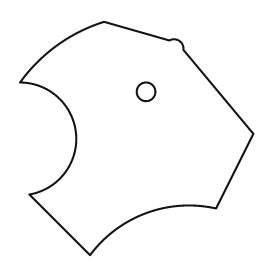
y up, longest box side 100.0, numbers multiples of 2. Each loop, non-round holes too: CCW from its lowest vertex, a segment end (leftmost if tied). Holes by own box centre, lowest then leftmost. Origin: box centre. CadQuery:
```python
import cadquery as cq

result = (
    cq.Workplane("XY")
    .moveTo(-20.0, -50.0)
    .threePointArc((4.0, -32.0), (34.0, -30.0))
    .lineTo(50.0, 2.0)
    .lineTo(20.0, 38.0)
    .threePointArc((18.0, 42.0), (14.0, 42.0))
    .lineTo(-14.0, 50.0)
    .threePointArc((-34.0, 40.0), (-50.0, 24.0))
    .threePointArc((-26.0, 2.0), (-46.0, -24.0))
    .close()
    .moveTo(4.0, 20.0)
    .circle(4.0)
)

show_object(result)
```